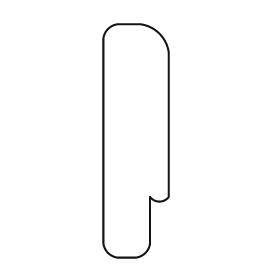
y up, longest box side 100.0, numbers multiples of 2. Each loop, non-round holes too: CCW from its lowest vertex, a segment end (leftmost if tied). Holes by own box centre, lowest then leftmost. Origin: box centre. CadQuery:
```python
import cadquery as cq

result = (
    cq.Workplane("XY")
    .moveTo(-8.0, -50.0)
    .lineTo(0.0, -50.0)
    .threePointArc((4.0, -48.0), (6.0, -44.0))
    .lineTo(6.0, -24.0)
    .threePointArc((10.0, -26.0), (14.0, -24.0))
    .lineTo(14.0, 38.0)
    .threePointArc((10.0, 46.0), (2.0, 50.0))
    .lineTo(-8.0, 50.0)
    .threePointArc((-12.0, 48.0), (-14.0, 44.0))
    .lineTo(-14.0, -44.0)
    .threePointArc((-12.0, -48.0), (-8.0, -50.0))
    .close()
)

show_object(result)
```